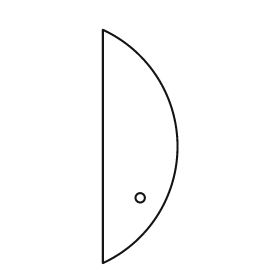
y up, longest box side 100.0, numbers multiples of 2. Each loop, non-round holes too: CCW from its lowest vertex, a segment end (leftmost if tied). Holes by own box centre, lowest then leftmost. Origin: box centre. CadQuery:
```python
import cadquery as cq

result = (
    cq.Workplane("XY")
    .moveTo(-16.0, -50.0)
    .threePointArc((16.0, 0.0), (-16.0, 50.0))
    .close()
    .moveTo(0.0, -22.0)
    .circle(2.0)
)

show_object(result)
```